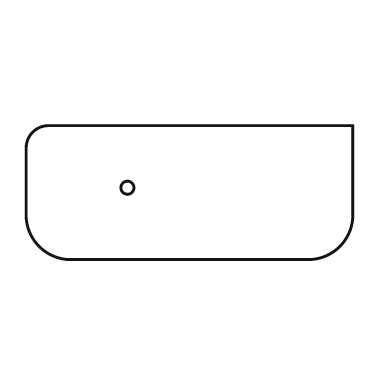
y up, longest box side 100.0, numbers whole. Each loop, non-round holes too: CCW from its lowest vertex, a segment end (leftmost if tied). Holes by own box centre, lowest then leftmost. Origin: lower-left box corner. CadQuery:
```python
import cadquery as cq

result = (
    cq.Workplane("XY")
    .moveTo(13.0, 0.0)
    .lineTo(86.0, 0.0)
    .threePointArc((96.0, 4.0), (100.0, 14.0))
    .lineTo(100.0, 41.0)
    .lineTo(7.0, 41.0)
    .threePointArc((2.0, 39.0), (0.0, 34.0))
    .lineTo(0.0, 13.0)
    .threePointArc((4.0, 4.0), (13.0, 0.0))
    .close()
    .moveTo(31.0, 22.0)
    .circle(2.0)
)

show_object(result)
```